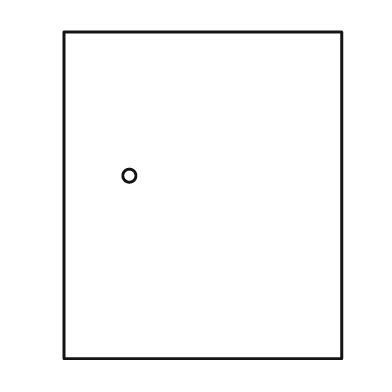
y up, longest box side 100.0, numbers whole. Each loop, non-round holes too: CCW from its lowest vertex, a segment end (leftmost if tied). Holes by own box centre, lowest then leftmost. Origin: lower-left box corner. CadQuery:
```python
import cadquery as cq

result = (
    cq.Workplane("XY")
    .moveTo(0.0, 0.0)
    .lineTo(85.0, 0.0)
    .lineTo(85.0, 100.0)
    .lineTo(0.0, 100.0)
    .close()
    .moveTo(20.0, 56.0)
    .circle(2.0)
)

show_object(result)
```